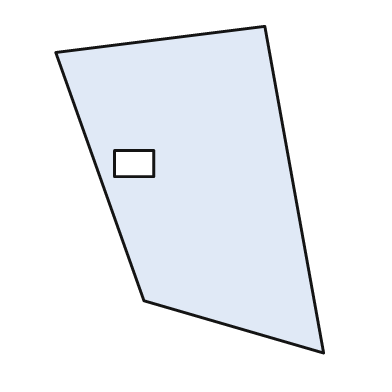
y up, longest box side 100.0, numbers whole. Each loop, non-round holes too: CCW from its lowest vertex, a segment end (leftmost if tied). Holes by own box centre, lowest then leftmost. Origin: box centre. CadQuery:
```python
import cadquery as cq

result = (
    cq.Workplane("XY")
    .moveTo(41.0, -50.0)
    .lineTo(23.0, 50.0)
    .lineTo(-41.0, 42.0)
    .lineTo(-14.0, -34.0)
    .close()
    .moveTo(-23.0, 4.0)
    .lineTo(-11.0, 4.0)
    .lineTo(-11.0, 12.0)
    .lineTo(-23.0, 12.0)
    .close()
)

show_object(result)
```